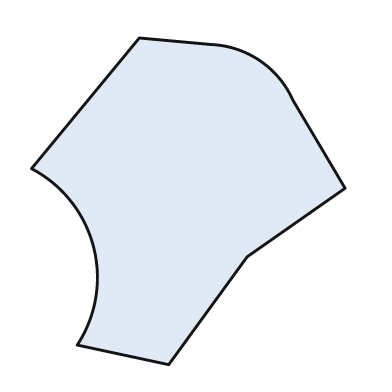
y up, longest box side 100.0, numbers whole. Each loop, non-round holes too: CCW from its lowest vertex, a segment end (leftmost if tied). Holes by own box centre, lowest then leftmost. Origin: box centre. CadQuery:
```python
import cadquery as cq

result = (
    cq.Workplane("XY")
    .moveTo(-6.0, -50.0)
    .lineTo(18.0, -17.0)
    .lineTo(48.0, 4.0)
    .lineTo(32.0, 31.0)
    .threePointArc((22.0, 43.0), (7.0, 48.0))
    .lineTo(-15.0, 50.0)
    .lineTo(-48.0, 10.0)
    .threePointArc((-29.0, -14.0), (-34.0, -44.0))
    .close()
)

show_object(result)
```